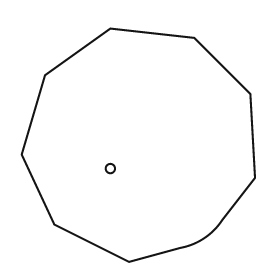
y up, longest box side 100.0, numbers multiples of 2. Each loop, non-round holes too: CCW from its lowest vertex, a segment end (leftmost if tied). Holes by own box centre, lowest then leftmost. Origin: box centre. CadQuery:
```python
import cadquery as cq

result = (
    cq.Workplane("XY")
    .moveTo(-4.0, -50.0)
    .lineTo(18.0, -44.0)
    .threePointArc((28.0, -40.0), (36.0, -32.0))
    .lineTo(50.0, -14.0)
    .lineTo(48.0, 22.0)
    .lineTo(24.0, 46.0)
    .lineTo(-12.0, 50.0)
    .lineTo(-40.0, 30.0)
    .lineTo(-50.0, -4.0)
    .lineTo(-36.0, -34.0)
    .close()
    .moveTo(-12.0, -10.0)
    .circle(2.0)
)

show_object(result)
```